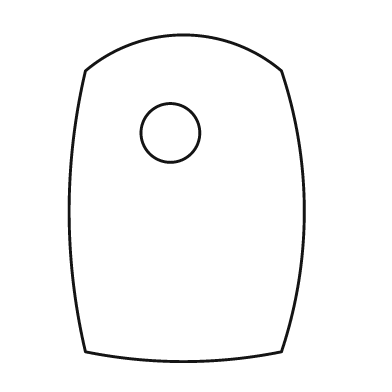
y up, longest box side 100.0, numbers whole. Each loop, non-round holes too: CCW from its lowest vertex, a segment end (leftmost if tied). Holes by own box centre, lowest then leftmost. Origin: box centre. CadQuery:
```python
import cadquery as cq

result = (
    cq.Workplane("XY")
    .moveTo(-31.0, -47.0)
    .threePointArc((-1.0, -50.0), (29.0, -47.0))
    .threePointArc((36.0, -4.0), (29.0, 39.0))
    .threePointArc((-1.0, 50.0), (-31.0, 39.0))
    .threePointArc((-36.0, -4.0), (-31.0, -47.0))
    .close()
    .moveTo(-5.0, 20.0)
    .circle(9.0)
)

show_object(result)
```